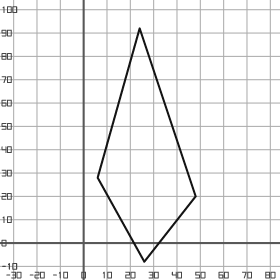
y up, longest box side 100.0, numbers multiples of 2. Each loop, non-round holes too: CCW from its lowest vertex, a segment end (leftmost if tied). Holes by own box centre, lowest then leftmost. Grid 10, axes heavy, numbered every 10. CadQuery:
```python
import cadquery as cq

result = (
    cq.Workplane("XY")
    .moveTo(26.0, -8.0)
    .lineTo(48.0, 20.0)
    .lineTo(24.0, 92.0)
    .lineTo(6.0, 28.0)
    .close()
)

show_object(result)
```